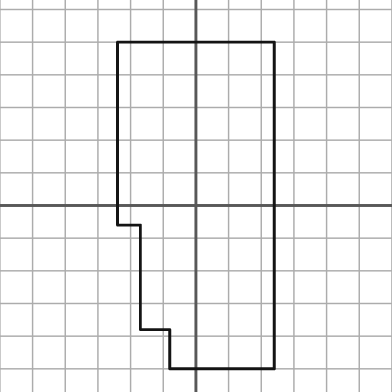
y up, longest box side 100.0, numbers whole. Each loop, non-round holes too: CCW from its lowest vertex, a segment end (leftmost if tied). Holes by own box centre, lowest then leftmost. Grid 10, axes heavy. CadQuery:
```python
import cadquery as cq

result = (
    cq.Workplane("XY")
    .moveTo(-8.0, -50.0)
    .lineTo(24.0, -50.0)
    .lineTo(24.0, 50.0)
    .lineTo(-24.0, 50.0)
    .lineTo(-24.0, -6.0)
    .lineTo(-17.0, -6.0)
    .lineTo(-17.0, -38.0)
    .lineTo(-8.0, -38.0)
    .close()
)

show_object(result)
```